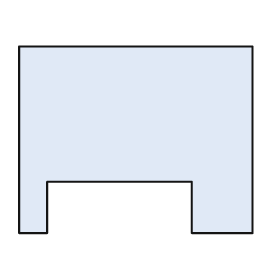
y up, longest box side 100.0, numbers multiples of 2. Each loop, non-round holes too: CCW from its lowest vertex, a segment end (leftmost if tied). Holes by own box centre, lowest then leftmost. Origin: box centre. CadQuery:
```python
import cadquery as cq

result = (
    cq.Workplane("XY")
    .moveTo(-50.0, -40.0)
    .lineTo(-38.0, -40.0)
    .lineTo(-38.0, -18.0)
    .lineTo(24.0, -18.0)
    .lineTo(24.0, -40.0)
    .lineTo(50.0, -40.0)
    .lineTo(50.0, 40.0)
    .lineTo(-50.0, 40.0)
    .close()
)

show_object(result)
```